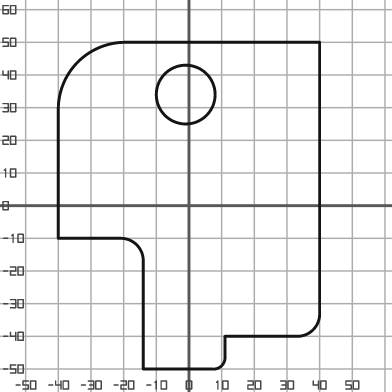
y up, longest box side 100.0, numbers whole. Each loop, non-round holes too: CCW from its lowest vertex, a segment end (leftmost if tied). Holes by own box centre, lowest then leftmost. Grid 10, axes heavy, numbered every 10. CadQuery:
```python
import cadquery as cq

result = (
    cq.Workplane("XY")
    .moveTo(-14.0, -50.0)
    .lineTo(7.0, -50.0)
    .threePointArc((10.0, -49.0), (11.0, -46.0))
    .lineTo(11.0, -40.0)
    .lineTo(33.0, -40.0)
    .threePointArc((38.0, -38.0), (40.0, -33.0))
    .lineTo(40.0, 50.0)
    .lineTo(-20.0, 50.0)
    .threePointArc((-34.0, 44.0), (-40.0, 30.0))
    .lineTo(-40.0, -10.0)
    .lineTo(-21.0, -10.0)
    .threePointArc((-16.0, -12.0), (-14.0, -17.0))
    .close()
    .moveTo(-1.0, 34.0)
    .circle(9.0)
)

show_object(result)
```